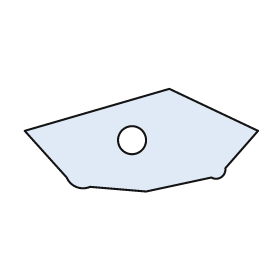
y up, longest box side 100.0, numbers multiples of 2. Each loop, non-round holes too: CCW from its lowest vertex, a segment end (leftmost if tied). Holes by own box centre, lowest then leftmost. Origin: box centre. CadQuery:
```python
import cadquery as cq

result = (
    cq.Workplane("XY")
    .moveTo(2.0, -22.0)
    .lineTo(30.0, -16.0)
    .threePointArc((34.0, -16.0), (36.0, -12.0))
    .lineTo(50.0, 4.0)
    .lineTo(12.0, 22.0)
    .lineTo(-50.0, 4.0)
    .lineTo(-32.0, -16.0)
    .threePointArc((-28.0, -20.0), (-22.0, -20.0))
    .close()
    .moveTo(-4.0, 0.0)
    .circle(6.0)
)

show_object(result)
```